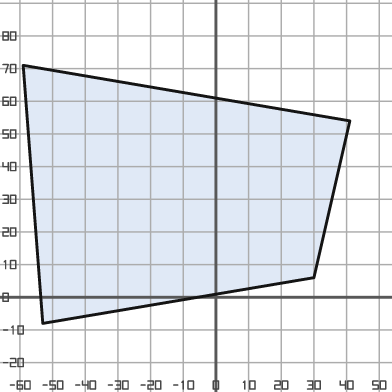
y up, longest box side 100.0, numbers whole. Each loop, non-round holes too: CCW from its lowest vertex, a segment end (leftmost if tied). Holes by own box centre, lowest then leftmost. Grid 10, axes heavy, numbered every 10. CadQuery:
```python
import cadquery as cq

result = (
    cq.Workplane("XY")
    .moveTo(-53.0, -8.0)
    .lineTo(30.0, 6.0)
    .lineTo(41.0, 54.0)
    .lineTo(-59.0, 71.0)
    .close()
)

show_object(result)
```